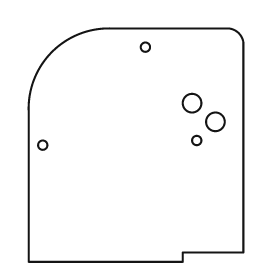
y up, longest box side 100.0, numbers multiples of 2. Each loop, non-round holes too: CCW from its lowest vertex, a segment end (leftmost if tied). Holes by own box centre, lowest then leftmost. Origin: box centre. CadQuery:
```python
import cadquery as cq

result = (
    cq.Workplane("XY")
    .moveTo(-46.0, -50.0)
    .lineTo(20.0, -50.0)
    .lineTo(20.0, -46.0)
    .lineTo(46.0, -46.0)
    .lineTo(46.0, 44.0)
    .threePointArc((44.0, 48.0), (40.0, 50.0))
    .lineTo(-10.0, 50.0)
    .threePointArc((-36.0, 40.0), (-46.0, 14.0))
    .close()
    .moveTo(-40.0, 0.0)
    .circle(2.0)
    .moveTo(26.0, 2.0)
    .circle(2.0)
    .moveTo(34.0, 10.0)
    .circle(4.0)
    .moveTo(24.0, 18.0)
    .circle(4.0)
    .moveTo(4.0, 42.0)
    .circle(2.0)
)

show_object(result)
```